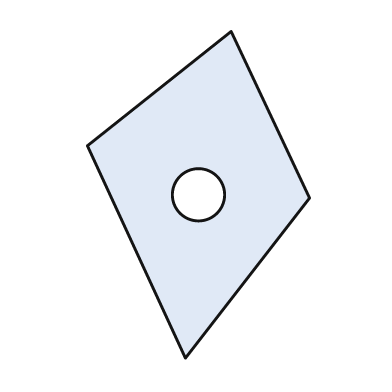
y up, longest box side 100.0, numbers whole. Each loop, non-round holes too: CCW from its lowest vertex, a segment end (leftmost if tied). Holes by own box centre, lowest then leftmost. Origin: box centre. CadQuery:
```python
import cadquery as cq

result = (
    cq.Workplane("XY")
    .moveTo(-4.0, -50.0)
    .lineTo(34.0, -1.0)
    .lineTo(10.0, 50.0)
    .lineTo(-34.0, 15.0)
    .close()
    .moveTo(0.0, 0.0)
    .circle(8.0)
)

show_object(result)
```